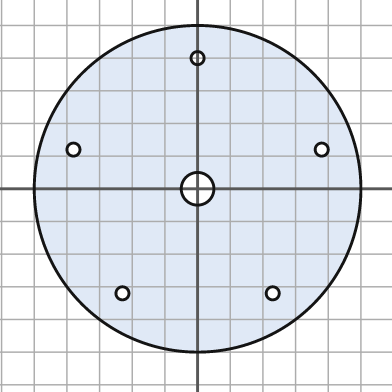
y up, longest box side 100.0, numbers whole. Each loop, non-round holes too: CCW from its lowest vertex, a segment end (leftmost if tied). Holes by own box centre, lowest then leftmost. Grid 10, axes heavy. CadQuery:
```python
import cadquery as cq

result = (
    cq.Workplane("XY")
    .moveTo(0.0, 0.0)
    .circle(50.0)
    .moveTo(-23.0, -32.0)
    .circle(2.0)
    .moveTo(23.0, -32.0)
    .circle(2.0)
    .moveTo(0.0, 0.0)
    .circle(5.0)
    .moveTo(-38.0, 12.0)
    .circle(2.0)
    .moveTo(38.0, 12.0)
    .circle(2.0)
    .moveTo(0.0, 40.0)
    .circle(2.0)
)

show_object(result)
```